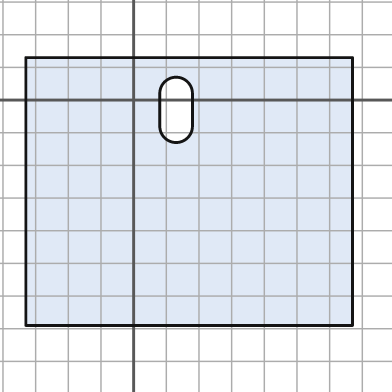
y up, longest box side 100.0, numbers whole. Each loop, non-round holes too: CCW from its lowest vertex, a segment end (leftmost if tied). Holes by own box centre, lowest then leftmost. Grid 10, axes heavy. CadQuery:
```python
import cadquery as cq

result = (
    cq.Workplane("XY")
    .moveTo(-33.0, -69.0)
    .lineTo(67.0, -69.0)
    .lineTo(67.0, 13.0)
    .lineTo(-33.0, 13.0)
    .close()
    .moveTo(8.0, -8.0)
    .threePointArc((13.0, -13.0), (18.0, -8.0))
    .lineTo(18.0, 2.0)
    .threePointArc((13.0, 7.0), (8.0, 2.0))
    .close()
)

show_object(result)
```